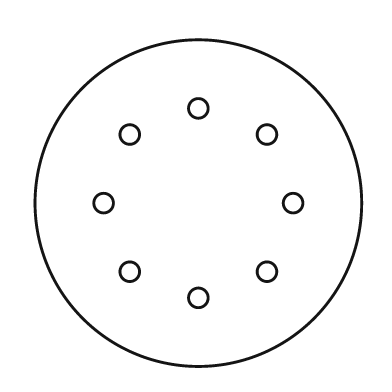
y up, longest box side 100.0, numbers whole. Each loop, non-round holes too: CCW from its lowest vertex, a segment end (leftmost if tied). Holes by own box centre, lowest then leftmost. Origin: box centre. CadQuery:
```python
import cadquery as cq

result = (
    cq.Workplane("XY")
    .moveTo(0.0, 0.0)
    .circle(50.0)
    .moveTo(0.0, -29.0)
    .circle(3.0)
    .moveTo(-21.0, -21.0)
    .circle(3.0)
    .moveTo(21.0, -21.0)
    .circle(3.0)
    .moveTo(-29.0, 0.0)
    .circle(3.0)
    .moveTo(29.0, 0.0)
    .circle(3.0)
    .moveTo(-21.0, 21.0)
    .circle(3.0)
    .moveTo(21.0, 21.0)
    .circle(3.0)
    .moveTo(0.0, 29.0)
    .circle(3.0)
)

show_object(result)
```